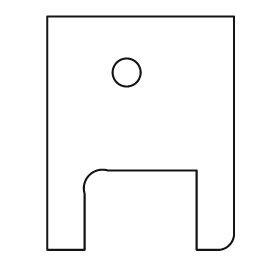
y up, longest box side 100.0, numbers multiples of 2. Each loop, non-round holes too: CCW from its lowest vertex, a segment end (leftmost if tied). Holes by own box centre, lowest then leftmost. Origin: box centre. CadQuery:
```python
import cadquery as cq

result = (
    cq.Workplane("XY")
    .moveTo(-40.0, -50.0)
    .lineTo(-24.0, -50.0)
    .lineTo(-24.0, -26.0)
    .threePointArc((-22.0, -18.0), (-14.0, -16.0))
    .lineTo(24.0, -16.0)
    .lineTo(24.0, -50.0)
    .lineTo(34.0, -50.0)
    .threePointArc((38.0, -48.0), (40.0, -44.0))
    .lineTo(40.0, 50.0)
    .lineTo(-40.0, 50.0)
    .close()
    .moveTo(-6.0, 26.0)
    .circle(6.0)
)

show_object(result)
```